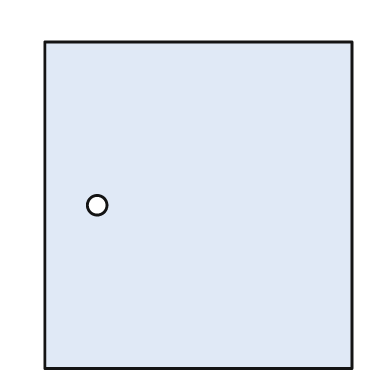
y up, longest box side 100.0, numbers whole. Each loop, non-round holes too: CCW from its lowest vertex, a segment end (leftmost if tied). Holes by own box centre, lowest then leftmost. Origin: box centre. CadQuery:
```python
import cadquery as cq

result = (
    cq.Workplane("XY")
    .moveTo(-47.0, -50.0)
    .lineTo(47.0, -50.0)
    .lineTo(47.0, 50.0)
    .lineTo(-47.0, 50.0)
    .close()
    .moveTo(-31.0, 0.0)
    .circle(3.0)
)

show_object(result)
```